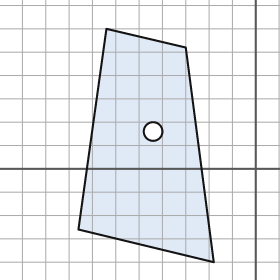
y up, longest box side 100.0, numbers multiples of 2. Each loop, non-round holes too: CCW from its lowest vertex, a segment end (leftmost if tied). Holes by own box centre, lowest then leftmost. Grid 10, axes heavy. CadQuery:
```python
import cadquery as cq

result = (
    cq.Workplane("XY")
    .moveTo(-18.0, -40.0)
    .lineTo(-30.0, 52.0)
    .lineTo(-64.0, 60.0)
    .lineTo(-76.0, -26.0)
    .close()
    .moveTo(-44.0, 16.0)
    .circle(4.0)
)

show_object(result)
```